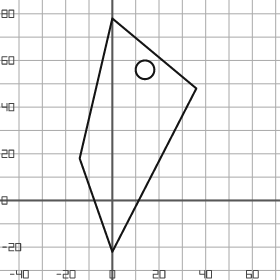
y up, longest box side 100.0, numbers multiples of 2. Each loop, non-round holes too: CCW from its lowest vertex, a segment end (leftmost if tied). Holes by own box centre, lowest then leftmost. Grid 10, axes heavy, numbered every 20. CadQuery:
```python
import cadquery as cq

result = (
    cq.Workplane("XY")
    .moveTo(0.0, -22.0)
    .lineTo(36.0, 48.0)
    .lineTo(0.0, 78.0)
    .lineTo(-14.0, 18.0)
    .close()
    .moveTo(14.0, 56.0)
    .circle(4.0)
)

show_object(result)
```